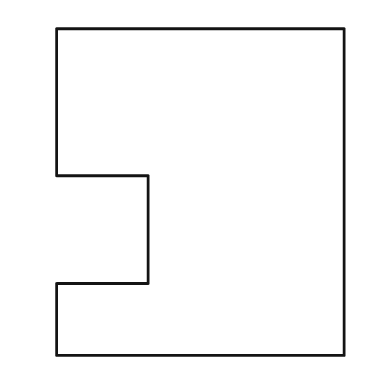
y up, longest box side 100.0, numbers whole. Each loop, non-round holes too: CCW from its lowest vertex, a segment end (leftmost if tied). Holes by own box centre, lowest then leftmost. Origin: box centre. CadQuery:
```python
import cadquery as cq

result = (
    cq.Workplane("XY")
    .moveTo(-44.0, -50.0)
    .lineTo(44.0, -50.0)
    .lineTo(44.0, 50.0)
    .lineTo(-44.0, 50.0)
    .lineTo(-44.0, 5.0)
    .lineTo(-16.0, 5.0)
    .lineTo(-16.0, -28.0)
    .lineTo(-44.0, -28.0)
    .close()
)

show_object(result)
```